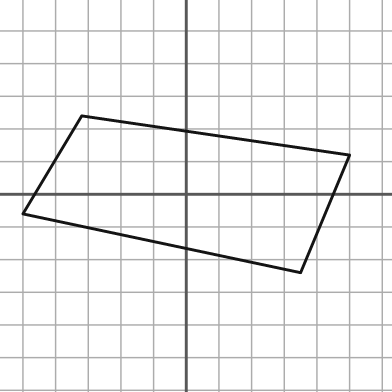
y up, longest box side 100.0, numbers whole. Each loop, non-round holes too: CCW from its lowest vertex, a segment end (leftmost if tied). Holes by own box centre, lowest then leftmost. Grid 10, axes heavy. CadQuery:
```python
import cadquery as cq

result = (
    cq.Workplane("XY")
    .moveTo(35.0, -24.0)
    .lineTo(50.0, 12.0)
    .lineTo(-32.0, 24.0)
    .lineTo(-50.0, -6.0)
    .close()
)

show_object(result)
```